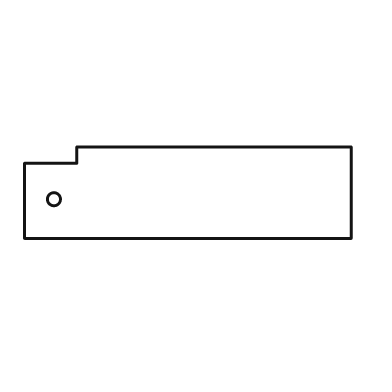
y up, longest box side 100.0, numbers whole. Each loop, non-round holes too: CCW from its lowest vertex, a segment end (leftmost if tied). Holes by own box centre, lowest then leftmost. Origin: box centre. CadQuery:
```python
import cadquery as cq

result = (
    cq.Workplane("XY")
    .moveTo(-50.0, -14.0)
    .lineTo(50.0, -14.0)
    .lineTo(50.0, 14.0)
    .lineTo(-34.0, 14.0)
    .lineTo(-34.0, 9.0)
    .lineTo(-50.0, 9.0)
    .close()
    .moveTo(-41.0, -2.0)
    .circle(2.0)
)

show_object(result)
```